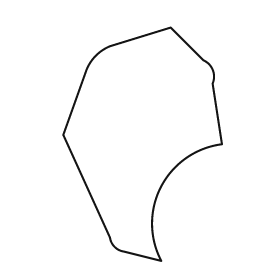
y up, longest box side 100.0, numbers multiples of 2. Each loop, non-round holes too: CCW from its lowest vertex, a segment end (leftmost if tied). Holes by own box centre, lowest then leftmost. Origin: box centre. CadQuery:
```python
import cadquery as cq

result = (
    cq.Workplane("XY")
    .moveTo(8.0, -50.0)
    .threePointArc((8.0, -18.0), (34.0, 0.0))
    .lineTo(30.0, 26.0)
    .threePointArc((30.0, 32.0), (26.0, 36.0))
    .lineTo(12.0, 50.0)
    .lineTo(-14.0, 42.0)
    .threePointArc((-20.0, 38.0), (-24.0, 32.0))
    .lineTo(-34.0, 4.0)
    .lineTo(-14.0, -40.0)
    .threePointArc((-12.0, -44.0), (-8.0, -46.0))
    .close()
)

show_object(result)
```